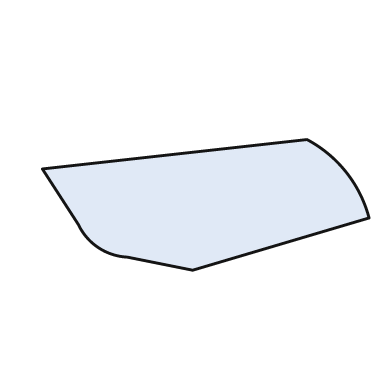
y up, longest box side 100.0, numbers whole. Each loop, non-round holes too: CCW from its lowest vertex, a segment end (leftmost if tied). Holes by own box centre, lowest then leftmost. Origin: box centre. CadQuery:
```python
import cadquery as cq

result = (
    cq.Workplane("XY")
    .moveTo(-4.0, -20.0)
    .lineTo(50.0, -4.0)
    .threePointArc((43.0, 10.0), (31.0, 20.0))
    .lineTo(-50.0, 11.0)
    .lineTo(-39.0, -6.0)
    .threePointArc((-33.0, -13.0), (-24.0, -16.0))
    .close()
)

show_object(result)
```